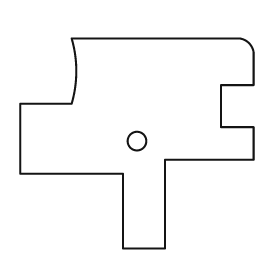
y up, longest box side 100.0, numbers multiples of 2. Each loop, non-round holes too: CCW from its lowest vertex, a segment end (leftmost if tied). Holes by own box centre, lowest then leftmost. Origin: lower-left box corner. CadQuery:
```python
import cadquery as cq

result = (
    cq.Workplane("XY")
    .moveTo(44.0, 0.0)
    .lineTo(62.0, 0.0)
    .lineTo(62.0, 38.0)
    .lineTo(100.0, 38.0)
    .lineTo(100.0, 52.0)
    .lineTo(86.0, 52.0)
    .lineTo(86.0, 70.0)
    .lineTo(100.0, 70.0)
    .lineTo(100.0, 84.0)
    .threePointArc((98.0, 88.0), (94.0, 90.0))
    .lineTo(22.0, 90.0)
    .threePointArc((24.0, 76.0), (22.0, 62.0))
    .lineTo(0.0, 62.0)
    .lineTo(0.0, 32.0)
    .lineTo(44.0, 32.0)
    .close()
    .moveTo(50.0, 46.0)
    .circle(4.0)
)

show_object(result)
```